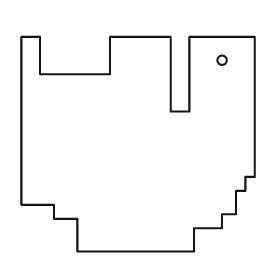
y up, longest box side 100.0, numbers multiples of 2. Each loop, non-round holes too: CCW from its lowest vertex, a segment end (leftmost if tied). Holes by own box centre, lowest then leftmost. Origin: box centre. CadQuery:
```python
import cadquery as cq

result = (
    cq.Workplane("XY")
    .moveTo(-26.0, -46.0)
    .lineTo(24.0, -46.0)
    .lineTo(24.0, -36.0)
    .lineTo(36.0, -36.0)
    .lineTo(36.0, -30.0)
    .lineTo(42.0, -30.0)
    .lineTo(42.0, -20.0)
    .lineTo(46.0, -20.0)
    .lineTo(46.0, -14.0)
    .lineTo(50.0, -14.0)
    .lineTo(50.0, 46.0)
    .lineTo(22.0, 46.0)
    .lineTo(22.0, 14.0)
    .lineTo(14.0, 14.0)
    .lineTo(14.0, 46.0)
    .lineTo(-12.0, 46.0)
    .lineTo(-12.0, 30.0)
    .lineTo(-42.0, 30.0)
    .lineTo(-42.0, 46.0)
    .lineTo(-50.0, 46.0)
    .lineTo(-50.0, -26.0)
    .lineTo(-36.0, -26.0)
    .lineTo(-36.0, -32.0)
    .lineTo(-26.0, -32.0)
    .close()
    .moveTo(36.0, 36.0)
    .circle(2.0)
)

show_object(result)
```